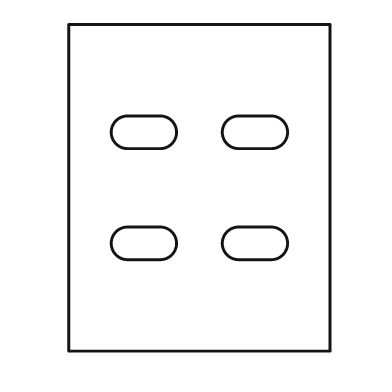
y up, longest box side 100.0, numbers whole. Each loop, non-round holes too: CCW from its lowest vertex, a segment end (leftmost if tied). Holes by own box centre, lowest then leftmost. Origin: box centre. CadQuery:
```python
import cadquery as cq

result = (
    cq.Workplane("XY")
    .moveTo(-40.0, -50.0)
    .lineTo(40.0, -50.0)
    .lineTo(40.0, 50.0)
    .lineTo(-40.0, 50.0)
    .close()
    .moveTo(-22.0, -22.0)
    .lineTo(-12.0, -22.0)
    .threePointArc((-7.0, -17.0), (-12.0, -12.0))
    .lineTo(-22.0, -12.0)
    .threePointArc((-27.0, -17.0), (-22.0, -22.0))
    .close()
    .moveTo(12.0, -22.0)
    .lineTo(22.0, -22.0)
    .threePointArc((27.0, -17.0), (22.0, -12.0))
    .lineTo(12.0, -12.0)
    .threePointArc((7.0, -17.0), (12.0, -22.0))
    .close()
    .moveTo(-22.0, 12.0)
    .lineTo(-12.0, 12.0)
    .threePointArc((-7.0, 17.0), (-12.0, 22.0))
    .lineTo(-22.0, 22.0)
    .threePointArc((-27.0, 17.0), (-22.0, 12.0))
    .close()
    .moveTo(12.0, 12.0)
    .lineTo(22.0, 12.0)
    .threePointArc((27.0, 17.0), (22.0, 22.0))
    .lineTo(12.0, 22.0)
    .threePointArc((7.0, 17.0), (12.0, 12.0))
    .close()
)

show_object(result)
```